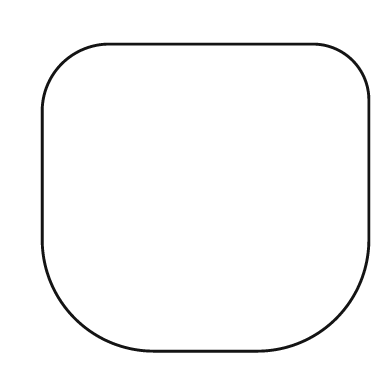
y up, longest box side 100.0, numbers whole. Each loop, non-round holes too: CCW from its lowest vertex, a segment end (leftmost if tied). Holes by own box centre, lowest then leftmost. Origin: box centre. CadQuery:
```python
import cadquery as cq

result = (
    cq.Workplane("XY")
    .moveTo(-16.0, -47.0)
    .lineTo(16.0, -47.0)
    .threePointArc((40.0, -37.0), (50.0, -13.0))
    .lineTo(50.0, 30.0)
    .threePointArc((45.0, 42.0), (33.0, 47.0))
    .lineTo(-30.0, 47.0)
    .threePointArc((-44.0, 41.0), (-50.0, 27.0))
    .lineTo(-50.0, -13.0)
    .threePointArc((-40.0, -37.0), (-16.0, -47.0))
    .close()
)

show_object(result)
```